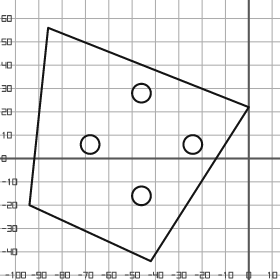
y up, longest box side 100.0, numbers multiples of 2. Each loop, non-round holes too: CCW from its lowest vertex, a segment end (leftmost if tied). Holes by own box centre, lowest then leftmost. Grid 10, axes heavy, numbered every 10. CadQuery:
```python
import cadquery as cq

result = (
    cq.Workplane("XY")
    .moveTo(-42.0, -44.0)
    .lineTo(0.0, 22.0)
    .lineTo(-86.0, 56.0)
    .lineTo(-94.0, -20.0)
    .close()
    .moveTo(-46.0, -16.0)
    .circle(4.0)
    .moveTo(-68.0, 6.0)
    .circle(4.0)
    .moveTo(-24.0, 6.0)
    .circle(4.0)
    .moveTo(-46.0, 28.0)
    .circle(4.0)
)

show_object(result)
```